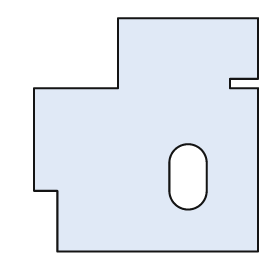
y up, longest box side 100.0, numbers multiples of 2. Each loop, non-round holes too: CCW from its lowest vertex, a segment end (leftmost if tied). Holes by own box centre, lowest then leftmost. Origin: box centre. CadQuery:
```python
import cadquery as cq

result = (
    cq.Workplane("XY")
    .moveTo(-38.0, -50.0)
    .lineTo(48.0, -50.0)
    .lineTo(48.0, 20.0)
    .lineTo(36.0, 20.0)
    .lineTo(36.0, 24.0)
    .lineTo(48.0, 24.0)
    .lineTo(48.0, 50.0)
    .lineTo(-12.0, 50.0)
    .lineTo(-12.0, 20.0)
    .lineTo(-48.0, 20.0)
    .lineTo(-48.0, -24.0)
    .lineTo(-38.0, -24.0)
    .close()
    .moveTo(10.0, -24.0)
    .threePointArc((18.0, -32.0), (26.0, -24.0))
    .lineTo(26.0, -12.0)
    .threePointArc((18.0, -4.0), (10.0, -12.0))
    .close()
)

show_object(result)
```